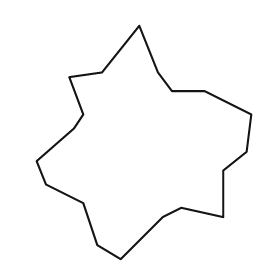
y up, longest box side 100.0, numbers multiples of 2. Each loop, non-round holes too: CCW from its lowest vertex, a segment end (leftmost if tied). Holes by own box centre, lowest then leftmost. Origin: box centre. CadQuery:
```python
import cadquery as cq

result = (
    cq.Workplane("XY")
    .moveTo(-10.0, -50.0)
    .lineTo(8.0, -32.0)
    .lineTo(16.0, -28.0)
    .lineTo(34.0, -32.0)
    .lineTo(34.0, -12.0)
    .lineTo(44.0, -4.0)
    .lineTo(46.0, 12.0)
    .lineTo(26.0, 22.0)
    .lineTo(12.0, 22.0)
    .lineTo(6.0, 30.0)
    .lineTo(-2.0, 50.0)
    .lineTo(-18.0, 30.0)
    .lineTo(-32.0, 28.0)
    .lineTo(-26.0, 12.0)
    .lineTo(-30.0, 6.0)
    .lineTo(-46.0, -8.0)
    .lineTo(-42.0, -18.0)
    .lineTo(-26.0, -26.0)
    .lineTo(-20.0, -44.0)
    .close()
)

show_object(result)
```